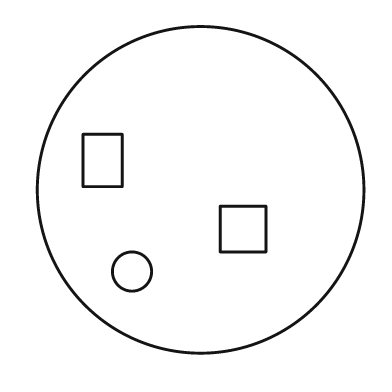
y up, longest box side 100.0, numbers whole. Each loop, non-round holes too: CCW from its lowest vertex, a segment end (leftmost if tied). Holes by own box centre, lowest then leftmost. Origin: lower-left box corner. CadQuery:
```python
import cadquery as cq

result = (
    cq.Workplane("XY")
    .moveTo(50.0, 50.0)
    .circle(50.0)
    .moveTo(29.0, 25.0)
    .circle(6.0)
    .moveTo(56.0, 31.0)
    .lineTo(70.0, 31.0)
    .lineTo(70.0, 45.0)
    .lineTo(56.0, 45.0)
    .close()
    .moveTo(14.0, 51.0)
    .lineTo(26.0, 51.0)
    .lineTo(26.0, 67.0)
    .lineTo(14.0, 67.0)
    .close()
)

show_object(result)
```